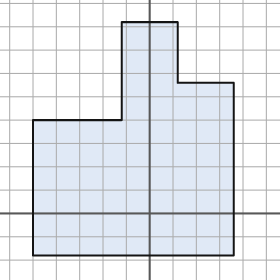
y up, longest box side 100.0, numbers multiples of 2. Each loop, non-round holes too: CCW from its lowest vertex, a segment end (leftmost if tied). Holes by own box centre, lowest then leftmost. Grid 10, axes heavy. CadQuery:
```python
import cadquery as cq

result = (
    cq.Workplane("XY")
    .moveTo(-50.0, -18.0)
    .lineTo(36.0, -18.0)
    .lineTo(36.0, 56.0)
    .lineTo(12.0, 56.0)
    .lineTo(12.0, 82.0)
    .lineTo(-12.0, 82.0)
    .lineTo(-12.0, 40.0)
    .lineTo(-50.0, 40.0)
    .close()
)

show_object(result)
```